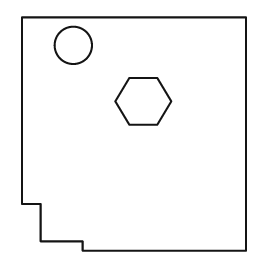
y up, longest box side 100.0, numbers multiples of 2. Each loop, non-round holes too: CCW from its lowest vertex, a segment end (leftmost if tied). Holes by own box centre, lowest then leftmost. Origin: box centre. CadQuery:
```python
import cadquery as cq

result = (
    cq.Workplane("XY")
    .moveTo(-22.0, -50.0)
    .lineTo(48.0, -50.0)
    .lineTo(48.0, 50.0)
    .lineTo(-48.0, 50.0)
    .lineTo(-48.0, -30.0)
    .lineTo(-40.0, -30.0)
    .lineTo(-40.0, -46.0)
    .lineTo(-22.0, -46.0)
    .close()
    .moveTo(-2.0, 4.0)
    .lineTo(10.0, 4.0)
    .lineTo(16.0, 14.0)
    .lineTo(10.0, 24.0)
    .lineTo(-2.0, 24.0)
    .lineTo(-8.0, 14.0)
    .close()
    .moveTo(-26.0, 38.0)
    .circle(8.0)
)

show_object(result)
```